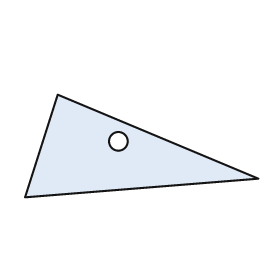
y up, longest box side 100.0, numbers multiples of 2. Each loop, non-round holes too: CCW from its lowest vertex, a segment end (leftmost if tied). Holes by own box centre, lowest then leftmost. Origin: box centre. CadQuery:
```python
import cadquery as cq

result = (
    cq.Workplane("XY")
    .moveTo(-50.0, -22.0)
    .lineTo(50.0, -14.0)
    .lineTo(-36.0, 22.0)
    .close()
    .moveTo(-10.0, 2.0)
    .circle(4.0)
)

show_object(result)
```